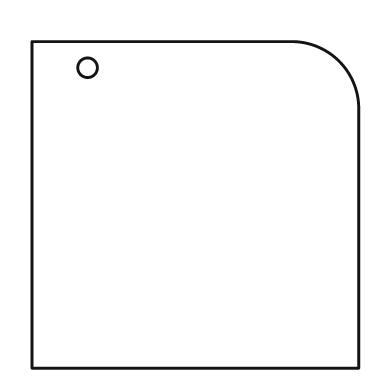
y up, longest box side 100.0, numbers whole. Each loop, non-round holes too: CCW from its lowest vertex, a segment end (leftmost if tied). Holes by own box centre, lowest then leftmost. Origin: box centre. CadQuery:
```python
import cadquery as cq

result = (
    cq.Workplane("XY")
    .moveTo(-50.0, -50.0)
    .lineTo(50.0, -50.0)
    .lineTo(50.0, 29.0)
    .threePointArc((44.0, 44.0), (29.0, 50.0))
    .lineTo(-50.0, 50.0)
    .close()
    .moveTo(-33.0, 42.0)
    .circle(3.0)
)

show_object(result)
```